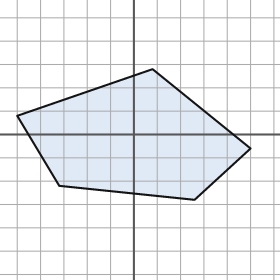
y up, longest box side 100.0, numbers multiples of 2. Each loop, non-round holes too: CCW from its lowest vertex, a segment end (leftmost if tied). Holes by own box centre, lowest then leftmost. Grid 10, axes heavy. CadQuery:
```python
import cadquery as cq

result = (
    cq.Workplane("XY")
    .moveTo(26.0, -28.0)
    .lineTo(50.0, -6.0)
    .lineTo(8.0, 28.0)
    .lineTo(-50.0, 8.0)
    .lineTo(-32.0, -22.0)
    .close()
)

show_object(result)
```